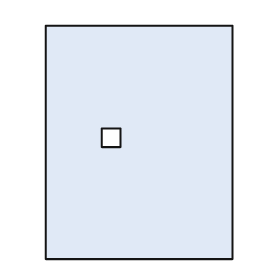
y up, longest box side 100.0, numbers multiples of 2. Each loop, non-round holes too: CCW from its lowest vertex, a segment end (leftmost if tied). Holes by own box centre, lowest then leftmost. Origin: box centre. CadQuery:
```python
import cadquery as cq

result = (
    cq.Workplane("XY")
    .moveTo(-40.0, -50.0)
    .lineTo(40.0, -50.0)
    .lineTo(40.0, 50.0)
    .lineTo(-40.0, 50.0)
    .close()
    .moveTo(-16.0, -2.0)
    .lineTo(-8.0, -2.0)
    .lineTo(-8.0, 6.0)
    .lineTo(-16.0, 6.0)
    .close()
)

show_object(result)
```